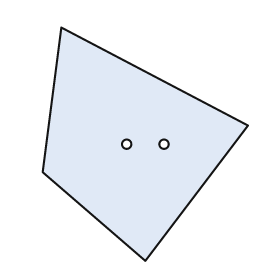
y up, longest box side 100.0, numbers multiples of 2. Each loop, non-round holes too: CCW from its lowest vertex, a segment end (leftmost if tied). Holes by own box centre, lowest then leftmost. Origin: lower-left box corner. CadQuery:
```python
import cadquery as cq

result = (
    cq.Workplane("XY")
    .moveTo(44.0, 0.0)
    .lineTo(88.0, 58.0)
    .lineTo(8.0, 100.0)
    .lineTo(0.0, 38.0)
    .close()
    .moveTo(36.0, 50.0)
    .circle(2.0)
    .moveTo(52.0, 50.0)
    .circle(2.0)
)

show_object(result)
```